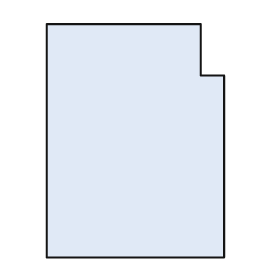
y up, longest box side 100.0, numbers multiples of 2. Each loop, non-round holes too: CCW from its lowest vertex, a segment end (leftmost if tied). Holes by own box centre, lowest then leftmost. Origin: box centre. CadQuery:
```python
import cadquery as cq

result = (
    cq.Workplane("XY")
    .moveTo(-38.0, -50.0)
    .lineTo(38.0, -50.0)
    .lineTo(38.0, 28.0)
    .lineTo(28.0, 28.0)
    .lineTo(28.0, 50.0)
    .lineTo(-38.0, 50.0)
    .close()
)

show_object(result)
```